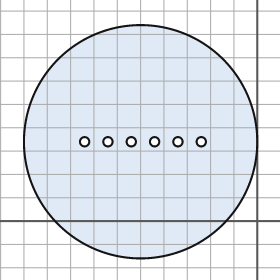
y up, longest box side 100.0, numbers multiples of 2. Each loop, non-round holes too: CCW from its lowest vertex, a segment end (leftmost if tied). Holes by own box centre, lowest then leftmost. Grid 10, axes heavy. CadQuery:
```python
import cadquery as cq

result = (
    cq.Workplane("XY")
    .moveTo(-50.0, 34.0)
    .circle(50.0)
    .moveTo(-74.0, 34.0)
    .circle(2.0)
    .moveTo(-64.0, 34.0)
    .circle(2.0)
    .moveTo(-54.0, 34.0)
    .circle(2.0)
    .moveTo(-44.0, 34.0)
    .circle(2.0)
    .moveTo(-34.0, 34.0)
    .circle(2.0)
    .moveTo(-24.0, 34.0)
    .circle(2.0)
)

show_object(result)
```